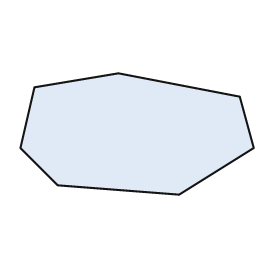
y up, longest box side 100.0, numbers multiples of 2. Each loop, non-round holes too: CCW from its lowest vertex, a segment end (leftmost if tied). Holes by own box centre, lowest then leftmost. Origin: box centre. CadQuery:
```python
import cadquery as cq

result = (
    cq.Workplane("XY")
    .moveTo(18.0, -26.0)
    .lineTo(50.0, -6.0)
    .lineTo(44.0, 16.0)
    .lineTo(-8.0, 26.0)
    .lineTo(-44.0, 20.0)
    .lineTo(-50.0, -6.0)
    .lineTo(-34.0, -22.0)
    .close()
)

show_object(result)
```